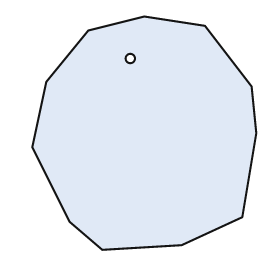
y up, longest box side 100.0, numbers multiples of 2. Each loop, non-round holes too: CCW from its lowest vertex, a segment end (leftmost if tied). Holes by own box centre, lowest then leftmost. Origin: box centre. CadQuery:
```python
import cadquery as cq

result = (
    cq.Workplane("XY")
    .moveTo(-18.0, -50.0)
    .lineTo(16.0, -48.0)
    .lineTo(42.0, -36.0)
    .lineTo(48.0, 0.0)
    .lineTo(46.0, 20.0)
    .lineTo(26.0, 46.0)
    .lineTo(0.0, 50.0)
    .lineTo(-24.0, 44.0)
    .lineTo(-42.0, 22.0)
    .lineTo(-48.0, -6.0)
    .lineTo(-32.0, -38.0)
    .close()
    .moveTo(-6.0, 32.0)
    .circle(2.0)
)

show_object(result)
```